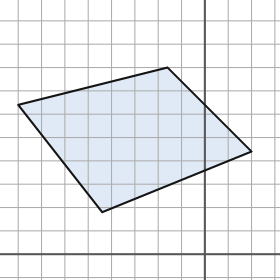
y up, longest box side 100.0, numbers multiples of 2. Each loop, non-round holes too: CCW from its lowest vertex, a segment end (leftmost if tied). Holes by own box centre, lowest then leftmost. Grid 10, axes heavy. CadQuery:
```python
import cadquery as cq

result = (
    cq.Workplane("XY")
    .moveTo(-44.0, 18.0)
    .lineTo(20.0, 44.0)
    .lineTo(-16.0, 80.0)
    .lineTo(-80.0, 64.0)
    .close()
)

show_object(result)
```